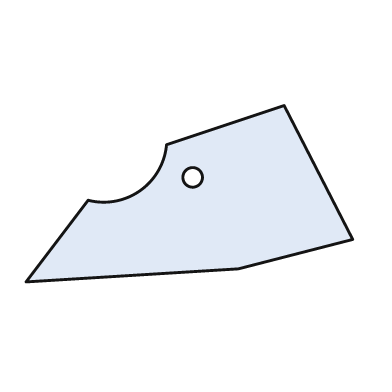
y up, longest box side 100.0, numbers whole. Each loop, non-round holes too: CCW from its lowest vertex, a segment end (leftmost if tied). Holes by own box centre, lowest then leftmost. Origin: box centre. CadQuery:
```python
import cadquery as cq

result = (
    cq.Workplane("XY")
    .moveTo(-50.0, -27.0)
    .lineTo(15.0, -23.0)
    .lineTo(50.0, -14.0)
    .lineTo(29.0, 27.0)
    .lineTo(-7.0, 15.0)
    .threePointArc((-15.0, 1.0), (-31.0, -2.0))
    .close()
    .moveTo(1.0, 5.0)
    .circle(3.0)
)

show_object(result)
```